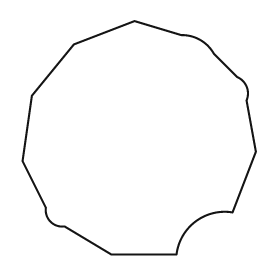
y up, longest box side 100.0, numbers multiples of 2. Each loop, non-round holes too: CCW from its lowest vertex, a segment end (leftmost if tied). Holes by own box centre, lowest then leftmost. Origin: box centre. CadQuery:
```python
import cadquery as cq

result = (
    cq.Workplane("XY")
    .moveTo(-12.0, -50.0)
    .lineTo(16.0, -50.0)
    .threePointArc((24.0, -36.0), (40.0, -32.0))
    .lineTo(50.0, -6.0)
    .lineTo(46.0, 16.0)
    .threePointArc((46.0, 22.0), (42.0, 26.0))
    .lineTo(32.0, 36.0)
    .threePointArc((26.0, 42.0), (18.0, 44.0))
    .lineTo(-2.0, 50.0)
    .lineTo(-28.0, 40.0)
    .lineTo(-46.0, 18.0)
    .lineTo(-50.0, -10.0)
    .lineTo(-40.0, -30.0)
    .threePointArc((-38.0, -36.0), (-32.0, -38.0))
    .close()
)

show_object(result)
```